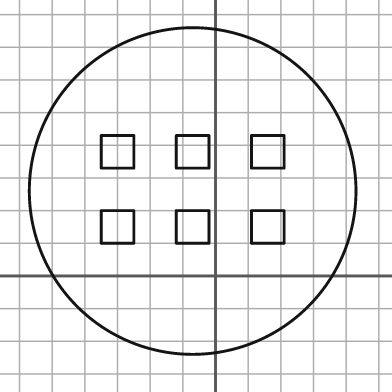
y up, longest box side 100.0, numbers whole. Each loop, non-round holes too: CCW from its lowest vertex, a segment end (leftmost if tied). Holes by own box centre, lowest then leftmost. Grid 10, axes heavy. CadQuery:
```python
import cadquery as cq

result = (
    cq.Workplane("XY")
    .moveTo(-7.0, 26.0)
    .circle(50.0)
    .moveTo(-35.0, 10.0)
    .lineTo(-25.0, 10.0)
    .lineTo(-25.0, 20.0)
    .lineTo(-35.0, 20.0)
    .close()
    .moveTo(-12.0, 10.0)
    .lineTo(-2.0, 10.0)
    .lineTo(-2.0, 20.0)
    .lineTo(-12.0, 20.0)
    .close()
    .moveTo(11.0, 10.0)
    .lineTo(21.0, 10.0)
    .lineTo(21.0, 20.0)
    .lineTo(11.0, 20.0)
    .close()
    .moveTo(-35.0, 33.0)
    .lineTo(-25.0, 33.0)
    .lineTo(-25.0, 43.0)
    .lineTo(-35.0, 43.0)
    .close()
    .moveTo(-12.0, 33.0)
    .lineTo(-2.0, 33.0)
    .lineTo(-2.0, 43.0)
    .lineTo(-12.0, 43.0)
    .close()
    .moveTo(11.0, 33.0)
    .lineTo(21.0, 33.0)
    .lineTo(21.0, 43.0)
    .lineTo(11.0, 43.0)
    .close()
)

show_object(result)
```